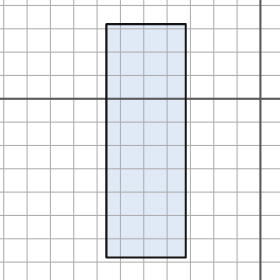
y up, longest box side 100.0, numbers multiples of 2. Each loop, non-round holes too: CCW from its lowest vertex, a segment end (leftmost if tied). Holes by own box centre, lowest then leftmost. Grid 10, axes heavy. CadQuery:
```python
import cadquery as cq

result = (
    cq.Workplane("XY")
    .moveTo(-66.0, -68.0)
    .lineTo(-32.0, -68.0)
    .lineTo(-32.0, 32.0)
    .lineTo(-66.0, 32.0)
    .close()
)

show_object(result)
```